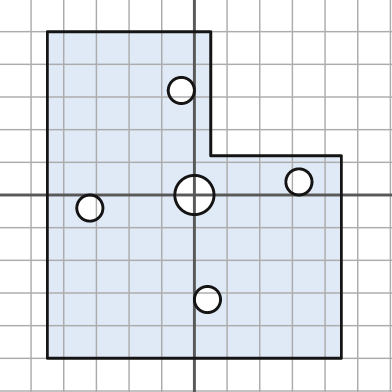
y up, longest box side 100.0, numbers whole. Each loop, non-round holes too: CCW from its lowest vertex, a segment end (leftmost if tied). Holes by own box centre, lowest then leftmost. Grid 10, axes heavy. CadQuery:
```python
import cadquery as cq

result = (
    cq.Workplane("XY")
    .moveTo(-45.0, -50.0)
    .lineTo(45.0, -50.0)
    .lineTo(45.0, 12.0)
    .lineTo(5.0, 12.0)
    .lineTo(5.0, 50.0)
    .lineTo(-45.0, 50.0)
    .close()
    .moveTo(4.0, -32.0)
    .circle(4.0)
    .moveTo(-32.0, -4.0)
    .circle(4.0)
    .moveTo(0.0, 0.0)
    .circle(6.0)
    .moveTo(32.0, 4.0)
    .circle(4.0)
    .moveTo(-4.0, 32.0)
    .circle(4.0)
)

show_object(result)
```